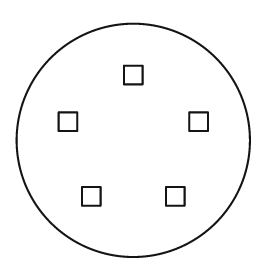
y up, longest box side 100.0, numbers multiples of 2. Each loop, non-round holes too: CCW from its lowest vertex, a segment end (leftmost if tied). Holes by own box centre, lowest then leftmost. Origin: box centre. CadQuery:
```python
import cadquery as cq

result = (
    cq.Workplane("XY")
    .moveTo(0.0, 0.0)
    .circle(50.0)
    .moveTo(-22.0, -28.0)
    .lineTo(-14.0, -28.0)
    .lineTo(-14.0, -20.0)
    .lineTo(-22.0, -20.0)
    .close()
    .moveTo(14.0, -28.0)
    .lineTo(22.0, -28.0)
    .lineTo(22.0, -20.0)
    .lineTo(14.0, -20.0)
    .close()
    .moveTo(-32.0, 4.0)
    .lineTo(-24.0, 4.0)
    .lineTo(-24.0, 12.0)
    .lineTo(-32.0, 12.0)
    .close()
    .moveTo(24.0, 4.0)
    .lineTo(32.0, 4.0)
    .lineTo(32.0, 12.0)
    .lineTo(24.0, 12.0)
    .close()
    .moveTo(-4.0, 24.0)
    .lineTo(4.0, 24.0)
    .lineTo(4.0, 32.0)
    .lineTo(-4.0, 32.0)
    .close()
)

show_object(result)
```